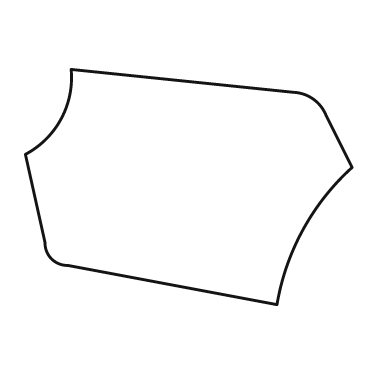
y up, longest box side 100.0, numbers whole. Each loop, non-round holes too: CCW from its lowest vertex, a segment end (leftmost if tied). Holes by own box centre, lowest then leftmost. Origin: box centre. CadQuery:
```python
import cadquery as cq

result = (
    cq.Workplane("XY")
    .moveTo(27.0, -36.0)
    .threePointArc((35.0, -13.0), (50.0, 6.0))
    .lineTo(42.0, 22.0)
    .threePointArc((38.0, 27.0), (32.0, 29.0))
    .lineTo(-36.0, 36.0)
    .threePointArc((-39.0, 21.0), (-50.0, 10.0))
    .lineTo(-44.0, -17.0)
    .threePointArc((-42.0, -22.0), (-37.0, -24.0))
    .close()
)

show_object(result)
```